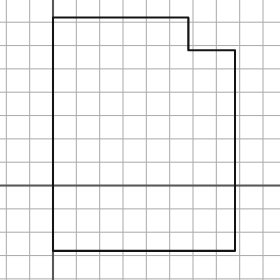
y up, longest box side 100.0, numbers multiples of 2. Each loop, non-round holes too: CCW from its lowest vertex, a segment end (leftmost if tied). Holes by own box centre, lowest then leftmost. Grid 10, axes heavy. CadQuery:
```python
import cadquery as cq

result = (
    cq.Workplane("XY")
    .moveTo(0.0, -28.0)
    .lineTo(78.0, -28.0)
    .lineTo(78.0, 58.0)
    .lineTo(58.0, 58.0)
    .lineTo(58.0, 72.0)
    .lineTo(0.0, 72.0)
    .close()
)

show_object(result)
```